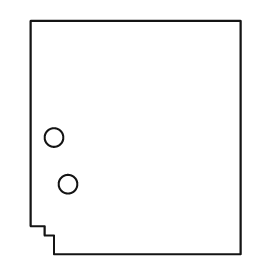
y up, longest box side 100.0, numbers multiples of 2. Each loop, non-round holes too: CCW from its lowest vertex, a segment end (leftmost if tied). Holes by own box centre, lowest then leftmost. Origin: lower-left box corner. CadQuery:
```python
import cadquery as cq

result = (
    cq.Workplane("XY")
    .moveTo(10.0, 0.0)
    .lineTo(90.0, 0.0)
    .lineTo(90.0, 100.0)
    .lineTo(0.0, 100.0)
    .lineTo(0.0, 12.0)
    .lineTo(6.0, 12.0)
    .lineTo(6.0, 8.0)
    .lineTo(10.0, 8.0)
    .close()
    .moveTo(16.0, 30.0)
    .circle(4.0)
    .moveTo(10.0, 50.0)
    .circle(4.0)
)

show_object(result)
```